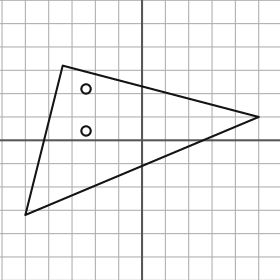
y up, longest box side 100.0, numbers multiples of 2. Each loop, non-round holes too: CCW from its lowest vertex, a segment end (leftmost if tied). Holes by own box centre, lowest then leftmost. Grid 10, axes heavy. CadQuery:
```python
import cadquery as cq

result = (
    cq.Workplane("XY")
    .moveTo(-50.0, -32.0)
    .lineTo(50.0, 10.0)
    .lineTo(-34.0, 32.0)
    .close()
    .moveTo(-24.0, 4.0)
    .circle(2.0)
    .moveTo(-24.0, 22.0)
    .circle(2.0)
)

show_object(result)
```